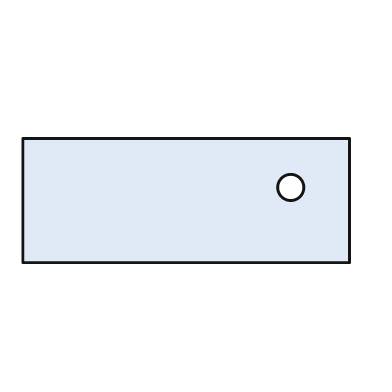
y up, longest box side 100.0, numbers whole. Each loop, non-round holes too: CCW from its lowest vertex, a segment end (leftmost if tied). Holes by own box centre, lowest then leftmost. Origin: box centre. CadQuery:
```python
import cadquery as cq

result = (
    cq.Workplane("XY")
    .moveTo(-50.0, -19.0)
    .lineTo(50.0, -19.0)
    .lineTo(50.0, 19.0)
    .lineTo(-50.0, 19.0)
    .close()
    .moveTo(32.0, 4.0)
    .circle(4.0)
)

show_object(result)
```